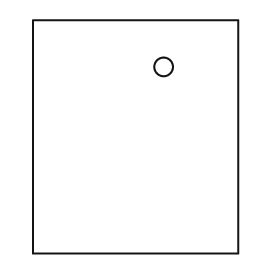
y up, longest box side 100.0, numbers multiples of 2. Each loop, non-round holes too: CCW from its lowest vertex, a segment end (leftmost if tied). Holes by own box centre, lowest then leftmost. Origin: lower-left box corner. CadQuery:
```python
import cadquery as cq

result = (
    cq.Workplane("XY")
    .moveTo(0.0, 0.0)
    .lineTo(88.0, 0.0)
    .lineTo(88.0, 100.0)
    .lineTo(0.0, 100.0)
    .close()
    .moveTo(56.0, 80.0)
    .circle(4.0)
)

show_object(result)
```